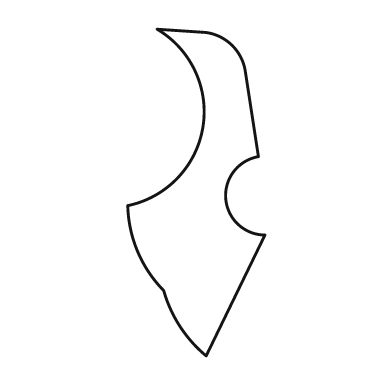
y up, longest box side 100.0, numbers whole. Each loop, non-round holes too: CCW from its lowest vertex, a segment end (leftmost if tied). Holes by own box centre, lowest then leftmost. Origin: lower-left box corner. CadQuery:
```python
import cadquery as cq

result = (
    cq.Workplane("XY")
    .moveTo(24.0, 0.0)
    .lineTo(42.0, 37.0)
    .threePointArc((30.0, 48.0), (40.0, 61.0))
    .lineTo(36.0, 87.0)
    .threePointArc((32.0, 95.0), (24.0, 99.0))
    .lineTo(9.0, 100.0)
    .threePointArc((23.0, 70.0), (0.0, 46.0))
    .threePointArc((3.0, 32.0), (11.0, 20.0))
    .threePointArc((16.0, 9.0), (24.0, 0.0))
    .close()
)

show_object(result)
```